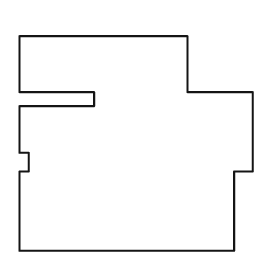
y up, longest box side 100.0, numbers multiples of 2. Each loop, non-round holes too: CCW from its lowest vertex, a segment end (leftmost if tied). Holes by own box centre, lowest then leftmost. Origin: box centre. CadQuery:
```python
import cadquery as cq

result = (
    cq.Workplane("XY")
    .moveTo(-50.0, -46.0)
    .lineTo(42.0, -46.0)
    .lineTo(42.0, -12.0)
    .lineTo(50.0, -12.0)
    .lineTo(50.0, 22.0)
    .lineTo(22.0, 22.0)
    .lineTo(22.0, 46.0)
    .lineTo(-50.0, 46.0)
    .lineTo(-50.0, 22.0)
    .lineTo(-18.0, 22.0)
    .lineTo(-18.0, 16.0)
    .lineTo(-50.0, 16.0)
    .lineTo(-50.0, -4.0)
    .lineTo(-46.0, -4.0)
    .lineTo(-46.0, -12.0)
    .lineTo(-50.0, -12.0)
    .close()
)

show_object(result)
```